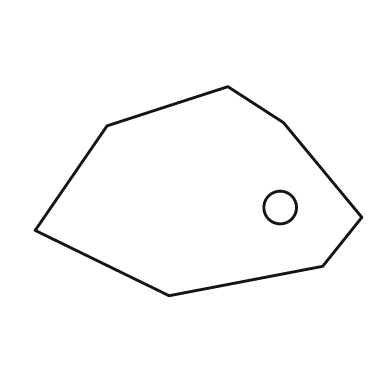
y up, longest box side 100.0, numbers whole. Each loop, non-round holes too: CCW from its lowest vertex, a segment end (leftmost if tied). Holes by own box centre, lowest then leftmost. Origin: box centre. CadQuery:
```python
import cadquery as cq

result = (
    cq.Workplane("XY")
    .moveTo(-9.0, -32.0)
    .lineTo(38.0, -23.0)
    .lineTo(50.0, -8.0)
    .lineTo(26.0, 21.0)
    .lineTo(9.0, 32.0)
    .lineTo(-28.0, 20.0)
    .lineTo(-50.0, -12.0)
    .close()
    .moveTo(25.0, -5.0)
    .circle(5.0)
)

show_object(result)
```